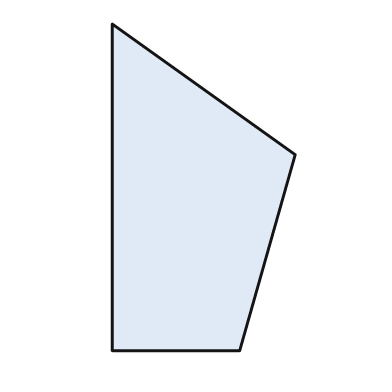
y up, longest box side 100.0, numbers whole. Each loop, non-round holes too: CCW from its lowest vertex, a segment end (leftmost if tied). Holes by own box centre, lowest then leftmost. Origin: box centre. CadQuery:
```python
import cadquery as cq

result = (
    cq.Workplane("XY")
    .moveTo(-28.0, -50.0)
    .lineTo(11.0, -50.0)
    .lineTo(28.0, 10.0)
    .lineTo(-28.0, 50.0)
    .close()
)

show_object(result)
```